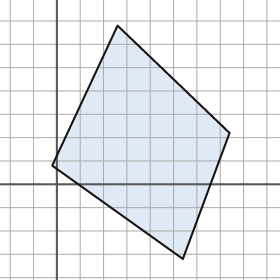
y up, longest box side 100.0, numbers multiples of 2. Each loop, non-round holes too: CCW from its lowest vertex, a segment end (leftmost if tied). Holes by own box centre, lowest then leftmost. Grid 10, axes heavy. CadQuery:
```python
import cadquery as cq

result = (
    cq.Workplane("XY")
    .moveTo(54.0, -32.0)
    .lineTo(74.0, 22.0)
    .lineTo(26.0, 68.0)
    .lineTo(-2.0, 8.0)
    .close()
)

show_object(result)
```